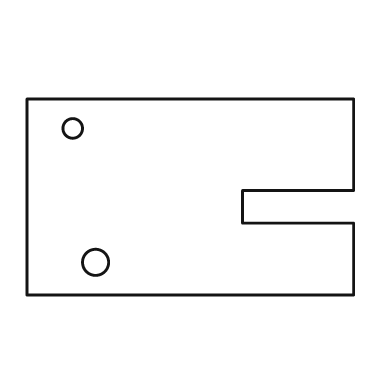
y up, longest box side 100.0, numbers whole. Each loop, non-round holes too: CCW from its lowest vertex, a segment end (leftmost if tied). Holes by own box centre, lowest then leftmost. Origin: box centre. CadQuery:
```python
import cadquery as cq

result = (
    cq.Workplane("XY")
    .moveTo(-50.0, -30.0)
    .lineTo(50.0, -30.0)
    .lineTo(50.0, -8.0)
    .lineTo(16.0, -8.0)
    .lineTo(16.0, 2.0)
    .lineTo(50.0, 2.0)
    .lineTo(50.0, 30.0)
    .lineTo(-50.0, 30.0)
    .close()
    .moveTo(-29.0, -20.0)
    .circle(4.0)
    .moveTo(-36.0, 21.0)
    .circle(3.0)
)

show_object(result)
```